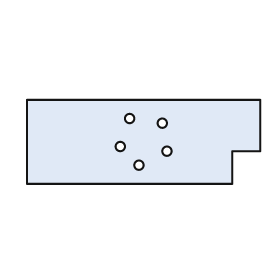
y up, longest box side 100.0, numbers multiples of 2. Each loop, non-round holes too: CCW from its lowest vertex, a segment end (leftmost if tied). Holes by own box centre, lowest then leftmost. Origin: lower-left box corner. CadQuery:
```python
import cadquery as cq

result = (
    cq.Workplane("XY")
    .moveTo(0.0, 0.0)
    .lineTo(88.0, 0.0)
    .lineTo(88.0, 14.0)
    .lineTo(100.0, 14.0)
    .lineTo(100.0, 36.0)
    .lineTo(0.0, 36.0)
    .close()
    .moveTo(48.0, 8.0)
    .circle(2.0)
    .moveTo(60.0, 14.0)
    .circle(2.0)
    .moveTo(40.0, 16.0)
    .circle(2.0)
    .moveTo(58.0, 26.0)
    .circle(2.0)
    .moveTo(44.0, 28.0)
    .circle(2.0)
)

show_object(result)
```